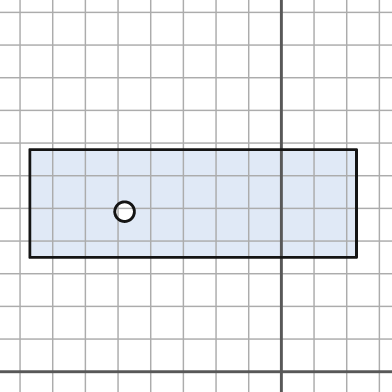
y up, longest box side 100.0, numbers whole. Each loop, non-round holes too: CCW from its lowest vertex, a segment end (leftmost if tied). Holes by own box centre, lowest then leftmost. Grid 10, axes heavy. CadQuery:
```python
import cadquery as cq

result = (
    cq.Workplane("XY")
    .moveTo(-77.0, 35.0)
    .lineTo(23.0, 35.0)
    .lineTo(23.0, 68.0)
    .lineTo(-77.0, 68.0)
    .close()
    .moveTo(-48.0, 49.0)
    .circle(3.0)
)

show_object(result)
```